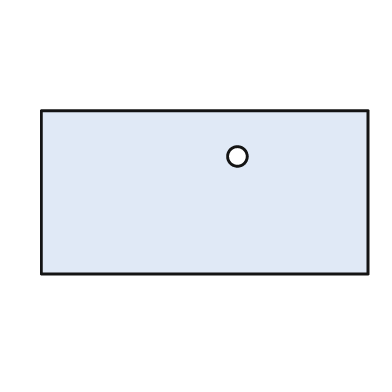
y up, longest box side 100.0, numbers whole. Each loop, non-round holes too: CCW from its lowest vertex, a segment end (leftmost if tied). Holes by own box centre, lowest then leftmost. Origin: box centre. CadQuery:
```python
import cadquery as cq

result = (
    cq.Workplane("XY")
    .moveTo(-50.0, -25.0)
    .lineTo(50.0, -25.0)
    .lineTo(50.0, 25.0)
    .lineTo(-50.0, 25.0)
    .close()
    .moveTo(10.0, 11.0)
    .circle(3.0)
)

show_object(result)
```